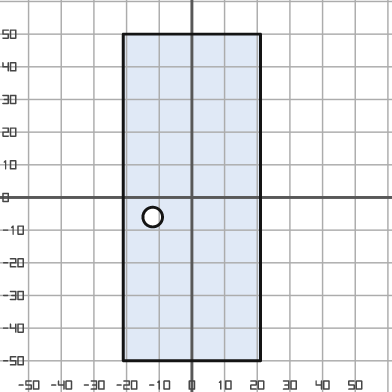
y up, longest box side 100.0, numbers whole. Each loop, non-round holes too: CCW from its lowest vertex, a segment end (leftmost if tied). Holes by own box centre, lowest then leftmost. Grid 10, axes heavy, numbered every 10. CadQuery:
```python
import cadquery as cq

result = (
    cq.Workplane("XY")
    .moveTo(-21.0, -50.0)
    .lineTo(21.0, -50.0)
    .lineTo(21.0, 50.0)
    .lineTo(-21.0, 50.0)
    .close()
    .moveTo(-12.0, -6.0)
    .circle(3.0)
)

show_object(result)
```